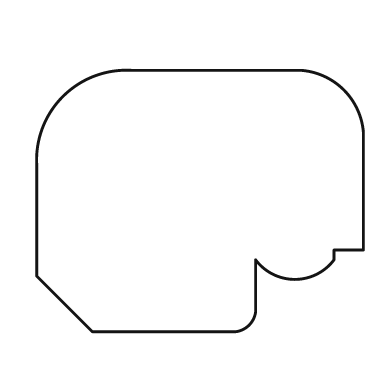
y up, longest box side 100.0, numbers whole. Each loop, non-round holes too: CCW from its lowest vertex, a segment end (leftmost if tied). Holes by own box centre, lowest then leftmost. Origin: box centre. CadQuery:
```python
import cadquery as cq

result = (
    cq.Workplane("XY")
    .moveTo(-33.0, -40.0)
    .lineTo(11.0, -40.0)
    .threePointArc((15.0, -38.0), (17.0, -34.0))
    .lineTo(17.0, -18.0)
    .threePointArc((29.0, -24.0), (41.0, -18.0))
    .lineTo(41.0, -15.0)
    .lineTo(50.0, -15.0)
    .lineTo(50.0, 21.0)
    .threePointArc((44.0, 34.0), (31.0, 40.0))
    .lineTo(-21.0, 40.0)
    .threePointArc((-42.0, 32.0), (-50.0, 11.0))
    .lineTo(-50.0, -23.0)
    .close()
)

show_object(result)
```